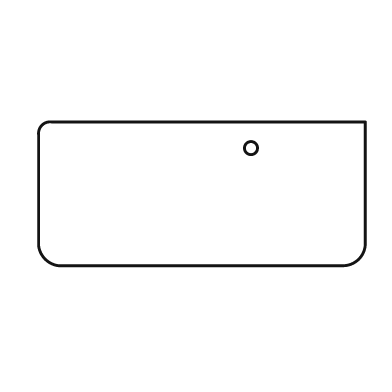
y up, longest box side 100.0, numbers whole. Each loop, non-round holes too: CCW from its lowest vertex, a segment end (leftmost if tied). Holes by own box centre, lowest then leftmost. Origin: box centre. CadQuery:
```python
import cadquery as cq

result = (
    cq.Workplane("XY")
    .moveTo(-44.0, -22.0)
    .lineTo(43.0, -22.0)
    .threePointArc((48.0, -20.0), (50.0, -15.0))
    .lineTo(50.0, 22.0)
    .lineTo(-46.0, 22.0)
    .threePointArc((-49.0, 21.0), (-50.0, 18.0))
    .lineTo(-50.0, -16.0)
    .threePointArc((-48.0, -20.0), (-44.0, -22.0))
    .close()
    .moveTo(15.0, 14.0)
    .circle(2.0)
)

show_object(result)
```